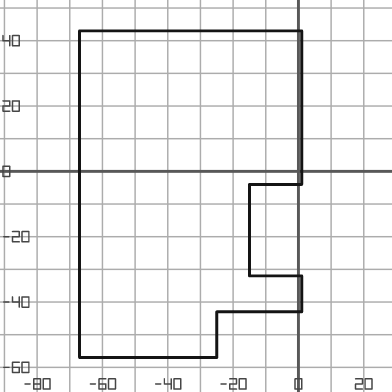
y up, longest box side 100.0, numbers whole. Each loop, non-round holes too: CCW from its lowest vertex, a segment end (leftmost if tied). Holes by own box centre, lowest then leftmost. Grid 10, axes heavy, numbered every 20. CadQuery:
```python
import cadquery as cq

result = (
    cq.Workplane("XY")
    .moveTo(-67.0, -57.0)
    .lineTo(-25.0, -57.0)
    .lineTo(-25.0, -43.0)
    .lineTo(1.0, -43.0)
    .lineTo(1.0, -32.0)
    .lineTo(-15.0, -32.0)
    .lineTo(-15.0, -4.0)
    .lineTo(1.0, -4.0)
    .lineTo(1.0, 43.0)
    .lineTo(-67.0, 43.0)
    .close()
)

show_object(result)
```